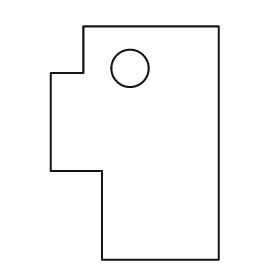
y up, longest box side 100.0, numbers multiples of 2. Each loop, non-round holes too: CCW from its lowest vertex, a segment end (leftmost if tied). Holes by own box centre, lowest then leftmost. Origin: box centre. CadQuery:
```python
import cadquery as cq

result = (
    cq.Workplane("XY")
    .moveTo(-14.0, -50.0)
    .lineTo(36.0, -50.0)
    .lineTo(36.0, 50.0)
    .lineTo(-22.0, 50.0)
    .lineTo(-22.0, 30.0)
    .lineTo(-36.0, 30.0)
    .lineTo(-36.0, -12.0)
    .lineTo(-14.0, -12.0)
    .close()
    .moveTo(-2.0, 32.0)
    .circle(8.0)
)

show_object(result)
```